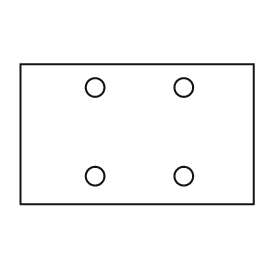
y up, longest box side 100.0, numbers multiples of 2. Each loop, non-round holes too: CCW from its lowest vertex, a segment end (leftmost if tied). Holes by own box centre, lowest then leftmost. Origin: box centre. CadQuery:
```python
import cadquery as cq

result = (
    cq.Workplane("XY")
    .moveTo(-50.0, -30.0)
    .lineTo(50.0, -30.0)
    .lineTo(50.0, 30.0)
    .lineTo(-50.0, 30.0)
    .close()
    .moveTo(-18.0, -18.0)
    .circle(4.0)
    .moveTo(20.0, -18.0)
    .circle(4.0)
    .moveTo(-18.0, 20.0)
    .circle(4.0)
    .moveTo(20.0, 20.0)
    .circle(4.0)
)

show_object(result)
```